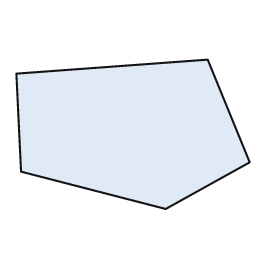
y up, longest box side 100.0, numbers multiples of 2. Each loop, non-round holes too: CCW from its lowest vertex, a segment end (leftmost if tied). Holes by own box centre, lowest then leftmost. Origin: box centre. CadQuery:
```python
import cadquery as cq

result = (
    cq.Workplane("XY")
    .moveTo(14.0, -32.0)
    .lineTo(50.0, -12.0)
    .lineTo(32.0, 32.0)
    .lineTo(-50.0, 26.0)
    .lineTo(-48.0, -16.0)
    .close()
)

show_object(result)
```